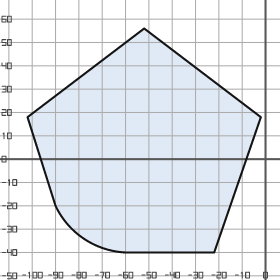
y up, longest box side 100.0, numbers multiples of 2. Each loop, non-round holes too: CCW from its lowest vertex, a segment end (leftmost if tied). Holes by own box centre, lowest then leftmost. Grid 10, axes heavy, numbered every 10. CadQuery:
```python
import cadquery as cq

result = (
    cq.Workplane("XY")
    .moveTo(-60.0, -40.0)
    .lineTo(-22.0, -40.0)
    .lineTo(-2.0, 18.0)
    .lineTo(-52.0, 56.0)
    .lineTo(-102.0, 18.0)
    .lineTo(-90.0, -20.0)
    .threePointArc((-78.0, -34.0), (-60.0, -40.0))
    .close()
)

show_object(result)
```